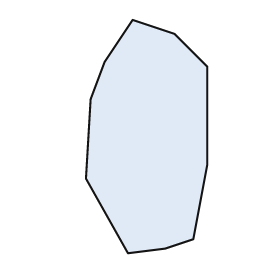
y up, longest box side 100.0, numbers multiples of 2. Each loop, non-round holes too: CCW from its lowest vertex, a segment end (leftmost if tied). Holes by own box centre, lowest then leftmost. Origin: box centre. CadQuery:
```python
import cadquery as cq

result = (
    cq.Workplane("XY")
    .moveTo(-8.0, -50.0)
    .lineTo(8.0, -48.0)
    .lineTo(20.0, -44.0)
    .lineTo(26.0, -12.0)
    .lineTo(26.0, 30.0)
    .lineTo(12.0, 44.0)
    .lineTo(-6.0, 50.0)
    .lineTo(-18.0, 32.0)
    .lineTo(-24.0, 16.0)
    .lineTo(-26.0, -18.0)
    .close()
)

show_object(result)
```